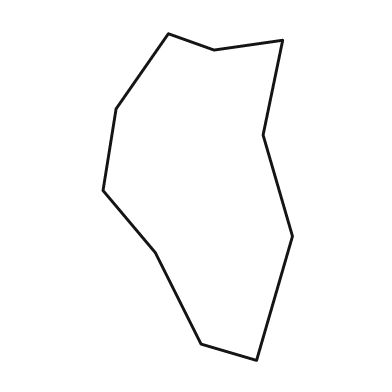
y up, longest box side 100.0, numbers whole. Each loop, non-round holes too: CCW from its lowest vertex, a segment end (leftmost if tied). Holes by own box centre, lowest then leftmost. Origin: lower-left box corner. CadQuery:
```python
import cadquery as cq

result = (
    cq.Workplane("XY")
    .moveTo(47.0, 0.0)
    .lineTo(58.0, 38.0)
    .lineTo(49.0, 69.0)
    .lineTo(55.0, 98.0)
    .lineTo(34.0, 95.0)
    .lineTo(20.0, 100.0)
    .lineTo(4.0, 77.0)
    .lineTo(0.0, 52.0)
    .lineTo(16.0, 33.0)
    .lineTo(30.0, 5.0)
    .close()
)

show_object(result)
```